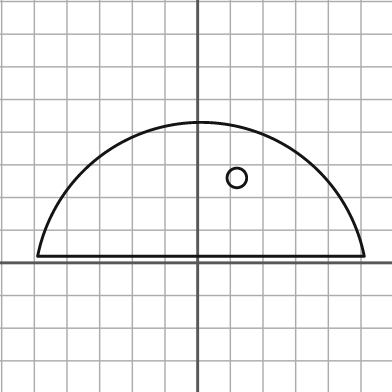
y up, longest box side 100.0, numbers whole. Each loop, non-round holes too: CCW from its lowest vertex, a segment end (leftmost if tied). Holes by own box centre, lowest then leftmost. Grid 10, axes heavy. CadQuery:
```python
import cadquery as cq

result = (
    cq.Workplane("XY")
    .moveTo(-49.0, 2.0)
    .lineTo(51.0, 2.0)
    .threePointArc((1.0, 43.0), (-49.0, 2.0))
    .close()
    .moveTo(12.0, 26.0)
    .circle(3.0)
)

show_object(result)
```